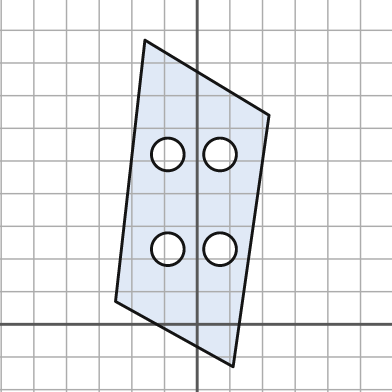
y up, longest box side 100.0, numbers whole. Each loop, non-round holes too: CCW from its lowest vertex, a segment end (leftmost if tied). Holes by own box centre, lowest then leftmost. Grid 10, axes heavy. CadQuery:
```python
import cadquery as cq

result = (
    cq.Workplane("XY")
    .moveTo(11.0, -13.0)
    .lineTo(22.0, 64.0)
    .lineTo(-16.0, 87.0)
    .lineTo(-25.0, 7.0)
    .close()
    .moveTo(-9.0, 23.0)
    .circle(5.0)
    .moveTo(7.0, 23.0)
    .circle(5.0)
    .moveTo(-9.0, 52.0)
    .circle(5.0)
    .moveTo(7.0, 52.0)
    .circle(5.0)
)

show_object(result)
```